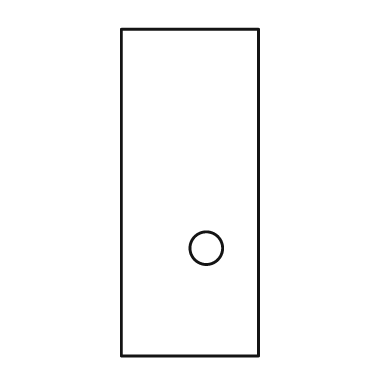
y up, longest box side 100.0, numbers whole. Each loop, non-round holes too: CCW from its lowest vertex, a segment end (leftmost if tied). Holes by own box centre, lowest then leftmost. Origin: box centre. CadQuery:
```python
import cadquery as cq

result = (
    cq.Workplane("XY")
    .moveTo(-21.0, -50.0)
    .lineTo(21.0, -50.0)
    .lineTo(21.0, 50.0)
    .lineTo(-21.0, 50.0)
    .close()
    .moveTo(5.0, -17.0)
    .circle(5.0)
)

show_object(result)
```